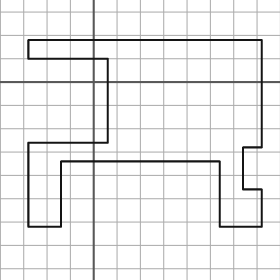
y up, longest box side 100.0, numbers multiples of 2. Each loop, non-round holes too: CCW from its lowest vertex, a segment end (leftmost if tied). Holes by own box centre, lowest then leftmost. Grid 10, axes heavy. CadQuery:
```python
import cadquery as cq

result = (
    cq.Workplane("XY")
    .moveTo(-28.0, -62.0)
    .lineTo(-14.0, -62.0)
    .lineTo(-14.0, -34.0)
    .lineTo(54.0, -34.0)
    .lineTo(54.0, -62.0)
    .lineTo(72.0, -62.0)
    .lineTo(72.0, -46.0)
    .lineTo(64.0, -46.0)
    .lineTo(64.0, -28.0)
    .lineTo(72.0, -28.0)
    .lineTo(72.0, 18.0)
    .lineTo(-28.0, 18.0)
    .lineTo(-28.0, 10.0)
    .lineTo(6.0, 10.0)
    .lineTo(6.0, -26.0)
    .lineTo(-28.0, -26.0)
    .close()
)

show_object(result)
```